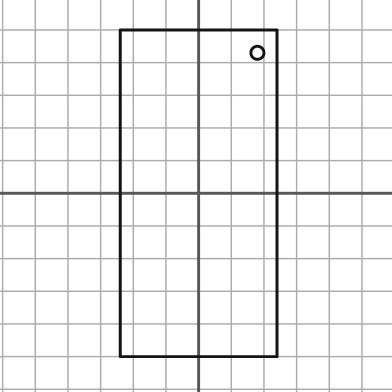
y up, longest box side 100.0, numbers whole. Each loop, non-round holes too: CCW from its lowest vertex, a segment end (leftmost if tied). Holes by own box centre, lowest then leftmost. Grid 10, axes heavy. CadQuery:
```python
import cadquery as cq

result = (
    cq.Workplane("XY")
    .moveTo(-24.0, -50.0)
    .lineTo(24.0, -50.0)
    .lineTo(24.0, 50.0)
    .lineTo(-24.0, 50.0)
    .close()
    .moveTo(18.0, 43.0)
    .circle(2.0)
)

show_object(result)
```